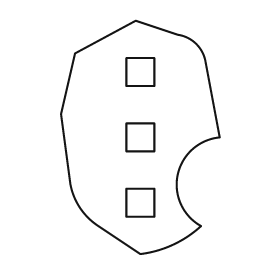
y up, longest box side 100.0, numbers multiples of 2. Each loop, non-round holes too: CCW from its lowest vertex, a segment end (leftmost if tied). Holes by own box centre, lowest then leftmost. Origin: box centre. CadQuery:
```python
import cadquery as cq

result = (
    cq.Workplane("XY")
    .moveTo(0.0, -50.0)
    .threePointArc((14.0, -46.0), (26.0, -38.0))
    .threePointArc((16.0, -16.0), (34.0, 0.0))
    .lineTo(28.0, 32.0)
    .threePointArc((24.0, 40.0), (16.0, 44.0))
    .lineTo(-2.0, 50.0)
    .lineTo(-28.0, 36.0)
    .lineTo(-34.0, 10.0)
    .lineTo(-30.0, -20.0)
    .threePointArc((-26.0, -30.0), (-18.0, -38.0))
    .close()
    .moveTo(-6.0, -34.0)
    .lineTo(6.0, -34.0)
    .lineTo(6.0, -22.0)
    .lineTo(-6.0, -22.0)
    .close()
    .moveTo(-6.0, -6.0)
    .lineTo(6.0, -6.0)
    .lineTo(6.0, 6.0)
    .lineTo(-6.0, 6.0)
    .close()
    .moveTo(-6.0, 22.0)
    .lineTo(6.0, 22.0)
    .lineTo(6.0, 34.0)
    .lineTo(-6.0, 34.0)
    .close()
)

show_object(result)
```